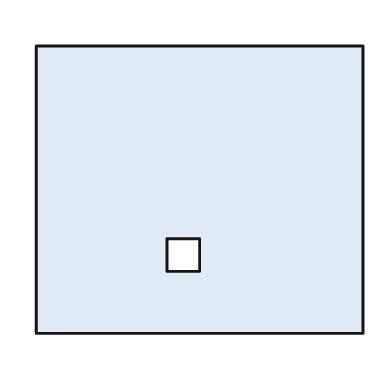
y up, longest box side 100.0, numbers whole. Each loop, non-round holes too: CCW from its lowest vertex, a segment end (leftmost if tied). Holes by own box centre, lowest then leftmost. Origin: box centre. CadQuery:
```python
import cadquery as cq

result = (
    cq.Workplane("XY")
    .moveTo(-50.0, -44.0)
    .lineTo(50.0, -44.0)
    .lineTo(50.0, 44.0)
    .lineTo(-50.0, 44.0)
    .close()
    .moveTo(-10.0, -25.0)
    .lineTo(0.0, -25.0)
    .lineTo(0.0, -15.0)
    .lineTo(-10.0, -15.0)
    .close()
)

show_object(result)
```